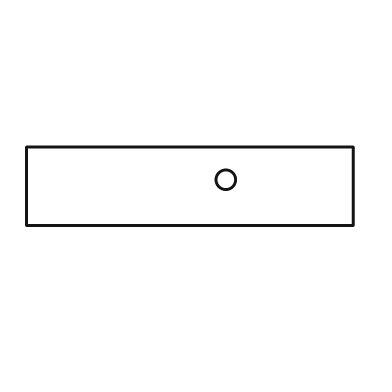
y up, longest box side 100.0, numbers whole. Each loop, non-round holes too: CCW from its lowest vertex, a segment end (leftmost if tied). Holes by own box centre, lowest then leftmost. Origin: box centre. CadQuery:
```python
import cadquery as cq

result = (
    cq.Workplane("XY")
    .moveTo(-50.0, -12.0)
    .lineTo(50.0, -12.0)
    .lineTo(50.0, 12.0)
    .lineTo(-50.0, 12.0)
    .close()
    .moveTo(11.0, 2.0)
    .circle(3.0)
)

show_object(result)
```